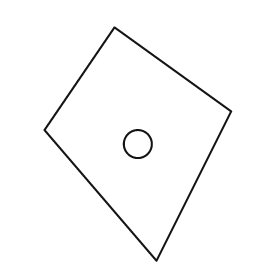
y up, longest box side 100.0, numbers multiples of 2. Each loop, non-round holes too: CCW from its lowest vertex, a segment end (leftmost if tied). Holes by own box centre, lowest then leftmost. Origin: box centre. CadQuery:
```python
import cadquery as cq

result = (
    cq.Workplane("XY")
    .moveTo(8.0, -50.0)
    .lineTo(40.0, 14.0)
    .lineTo(-10.0, 50.0)
    .lineTo(-40.0, 6.0)
    .close()
    .moveTo(0.0, 0.0)
    .circle(6.0)
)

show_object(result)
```